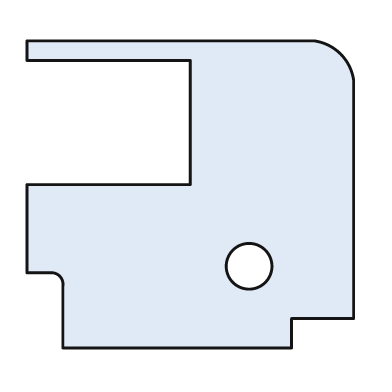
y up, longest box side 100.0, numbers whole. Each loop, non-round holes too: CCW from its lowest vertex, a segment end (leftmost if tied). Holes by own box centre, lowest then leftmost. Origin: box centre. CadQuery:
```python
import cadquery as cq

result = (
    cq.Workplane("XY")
    .moveTo(-39.0, -47.0)
    .lineTo(31.0, -47.0)
    .lineTo(31.0, -38.0)
    .lineTo(50.0, -38.0)
    .lineTo(50.0, 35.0)
    .threePointArc((46.0, 43.0), (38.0, 47.0))
    .lineTo(-50.0, 47.0)
    .lineTo(-50.0, 41.0)
    .lineTo(0.0, 41.0)
    .lineTo(0.0, 3.0)
    .lineTo(-50.0, 3.0)
    .lineTo(-50.0, -24.0)
    .lineTo(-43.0, -24.0)
    .threePointArc((-40.0, -25.0), (-39.0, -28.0))
    .close()
    .moveTo(18.0, -22.0)
    .circle(7.0)
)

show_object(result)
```